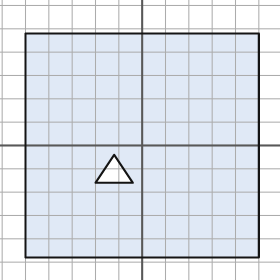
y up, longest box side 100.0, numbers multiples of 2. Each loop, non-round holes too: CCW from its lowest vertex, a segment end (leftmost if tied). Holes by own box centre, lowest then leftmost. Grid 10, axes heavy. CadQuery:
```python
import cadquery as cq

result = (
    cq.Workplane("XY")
    .moveTo(-50.0, -48.0)
    .lineTo(50.0, -48.0)
    .lineTo(50.0, 48.0)
    .lineTo(-50.0, 48.0)
    .close()
    .moveTo(-20.0, -16.0)
    .lineTo(-4.0, -16.0)
    .lineTo(-12.0, -4.0)
    .close()
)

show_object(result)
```